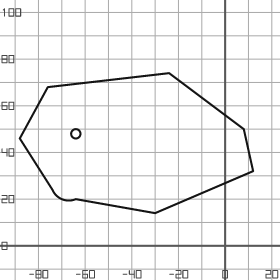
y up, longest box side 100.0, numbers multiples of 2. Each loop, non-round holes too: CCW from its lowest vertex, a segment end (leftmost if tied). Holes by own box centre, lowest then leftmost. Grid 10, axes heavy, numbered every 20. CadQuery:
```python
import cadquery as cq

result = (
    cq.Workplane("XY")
    .moveTo(-30.0, 14.0)
    .lineTo(12.0, 32.0)
    .lineTo(8.0, 50.0)
    .lineTo(-24.0, 74.0)
    .lineTo(-76.0, 68.0)
    .lineTo(-88.0, 46.0)
    .lineTo(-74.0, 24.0)
    .threePointArc((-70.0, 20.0), (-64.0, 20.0))
    .close()
    .moveTo(-64.0, 48.0)
    .circle(2.0)
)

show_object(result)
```